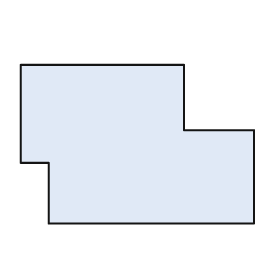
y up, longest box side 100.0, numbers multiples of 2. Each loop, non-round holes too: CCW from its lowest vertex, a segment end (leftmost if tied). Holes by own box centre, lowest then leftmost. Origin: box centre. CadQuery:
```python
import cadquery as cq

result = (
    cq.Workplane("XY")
    .moveTo(-38.0, -34.0)
    .lineTo(50.0, -34.0)
    .lineTo(50.0, 6.0)
    .lineTo(20.0, 6.0)
    .lineTo(20.0, 34.0)
    .lineTo(-50.0, 34.0)
    .lineTo(-50.0, -8.0)
    .lineTo(-38.0, -8.0)
    .close()
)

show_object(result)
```